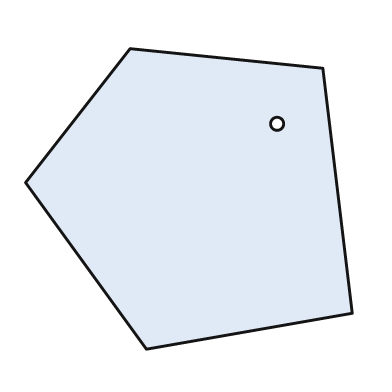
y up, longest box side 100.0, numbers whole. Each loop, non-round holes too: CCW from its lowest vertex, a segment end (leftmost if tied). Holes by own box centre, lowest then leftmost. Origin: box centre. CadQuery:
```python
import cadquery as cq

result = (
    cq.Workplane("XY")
    .moveTo(-13.0, -46.0)
    .lineTo(50.0, -35.0)
    .lineTo(41.0, 40.0)
    .lineTo(-18.0, 46.0)
    .lineTo(-50.0, 5.0)
    .close()
    .moveTo(27.0, 23.0)
    .circle(2.0)
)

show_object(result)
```